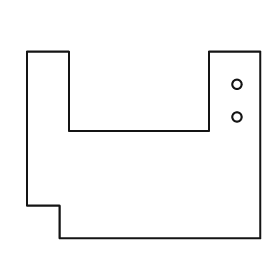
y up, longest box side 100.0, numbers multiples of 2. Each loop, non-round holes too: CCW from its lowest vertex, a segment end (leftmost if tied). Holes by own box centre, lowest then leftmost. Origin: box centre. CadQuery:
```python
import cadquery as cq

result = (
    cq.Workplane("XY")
    .moveTo(-36.0, -40.0)
    .lineTo(50.0, -40.0)
    .lineTo(50.0, 40.0)
    .lineTo(28.0, 40.0)
    .lineTo(28.0, 6.0)
    .lineTo(-32.0, 6.0)
    .lineTo(-32.0, 40.0)
    .lineTo(-50.0, 40.0)
    .lineTo(-50.0, -26.0)
    .lineTo(-36.0, -26.0)
    .close()
    .moveTo(40.0, 12.0)
    .circle(2.0)
    .moveTo(40.0, 26.0)
    .circle(2.0)
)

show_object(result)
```